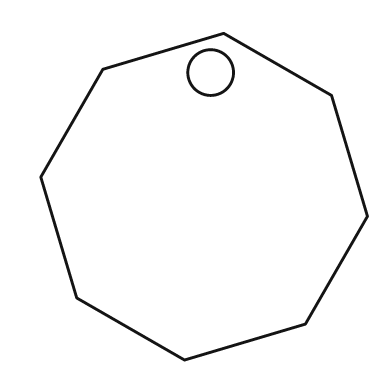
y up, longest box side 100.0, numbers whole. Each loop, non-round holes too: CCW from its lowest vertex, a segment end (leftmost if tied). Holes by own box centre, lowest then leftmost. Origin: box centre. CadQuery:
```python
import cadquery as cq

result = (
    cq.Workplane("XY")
    .moveTo(-6.0, -50.0)
    .lineTo(31.0, -39.0)
    .lineTo(50.0, -6.0)
    .lineTo(39.0, 31.0)
    .lineTo(6.0, 50.0)
    .lineTo(-31.0, 39.0)
    .lineTo(-50.0, 6.0)
    .lineTo(-39.0, -31.0)
    .close()
    .moveTo(2.0, 38.0)
    .circle(7.0)
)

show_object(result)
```